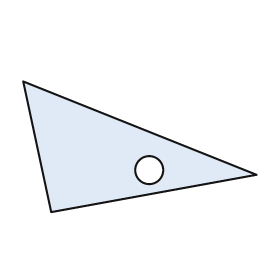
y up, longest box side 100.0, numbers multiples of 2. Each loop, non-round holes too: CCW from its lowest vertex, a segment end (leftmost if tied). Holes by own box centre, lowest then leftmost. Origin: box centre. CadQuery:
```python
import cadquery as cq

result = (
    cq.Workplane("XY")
    .moveTo(-38.0, -28.0)
    .lineTo(50.0, -12.0)
    .lineTo(-50.0, 28.0)
    .close()
    .moveTo(4.0, -10.0)
    .circle(6.0)
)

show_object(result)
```